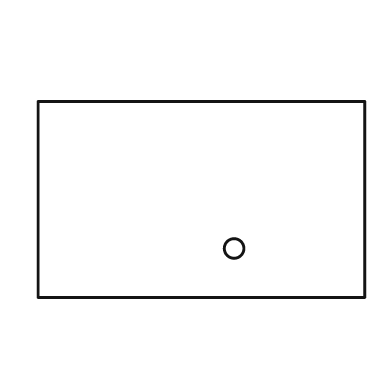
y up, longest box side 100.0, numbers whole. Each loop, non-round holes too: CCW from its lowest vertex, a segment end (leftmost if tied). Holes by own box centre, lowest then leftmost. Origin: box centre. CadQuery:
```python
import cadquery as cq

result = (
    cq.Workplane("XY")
    .moveTo(-50.0, -30.0)
    .lineTo(50.0, -30.0)
    .lineTo(50.0, 30.0)
    .lineTo(-50.0, 30.0)
    .close()
    .moveTo(10.0, -15.0)
    .circle(3.0)
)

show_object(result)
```